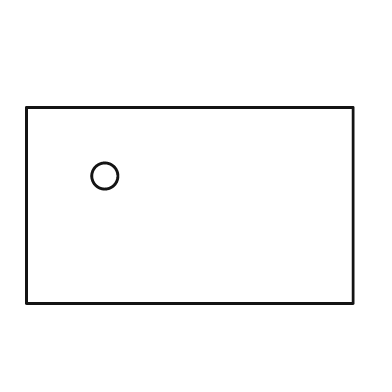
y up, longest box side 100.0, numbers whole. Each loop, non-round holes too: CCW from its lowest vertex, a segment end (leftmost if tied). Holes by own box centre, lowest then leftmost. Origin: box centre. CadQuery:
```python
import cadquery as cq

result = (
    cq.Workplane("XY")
    .moveTo(-50.0, -30.0)
    .lineTo(50.0, -30.0)
    .lineTo(50.0, 30.0)
    .lineTo(-50.0, 30.0)
    .close()
    .moveTo(-26.0, 9.0)
    .circle(4.0)
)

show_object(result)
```